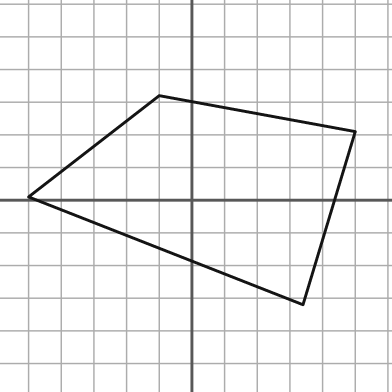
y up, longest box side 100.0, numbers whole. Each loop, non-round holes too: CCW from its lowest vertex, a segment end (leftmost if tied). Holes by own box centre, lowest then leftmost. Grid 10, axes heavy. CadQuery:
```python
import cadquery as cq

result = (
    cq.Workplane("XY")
    .moveTo(34.0, -32.0)
    .lineTo(50.0, 21.0)
    .lineTo(-10.0, 32.0)
    .lineTo(-50.0, 1.0)
    .close()
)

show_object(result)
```